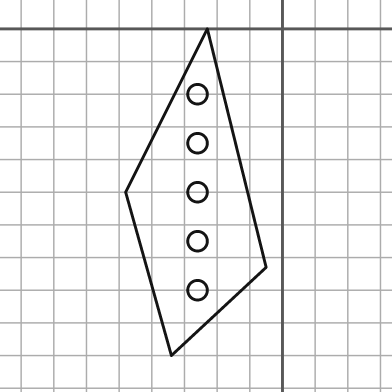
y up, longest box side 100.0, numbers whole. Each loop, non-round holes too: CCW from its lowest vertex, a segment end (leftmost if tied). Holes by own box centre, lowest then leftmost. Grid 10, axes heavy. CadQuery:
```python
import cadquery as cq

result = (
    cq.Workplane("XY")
    .moveTo(-34.0, -100.0)
    .lineTo(-5.0, -73.0)
    .lineTo(-23.0, 0.0)
    .lineTo(-48.0, -50.0)
    .close()
    .moveTo(-26.0, -80.0)
    .circle(3.0)
    .moveTo(-26.0, -65.0)
    .circle(3.0)
    .moveTo(-26.0, -50.0)
    .circle(3.0)
    .moveTo(-26.0, -35.0)
    .circle(3.0)
    .moveTo(-26.0, -20.0)
    .circle(3.0)
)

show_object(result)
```